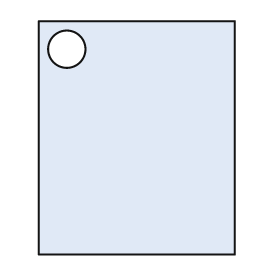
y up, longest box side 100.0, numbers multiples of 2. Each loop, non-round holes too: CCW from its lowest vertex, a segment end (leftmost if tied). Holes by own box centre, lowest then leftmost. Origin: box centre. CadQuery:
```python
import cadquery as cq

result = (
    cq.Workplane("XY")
    .moveTo(-42.0, -50.0)
    .lineTo(42.0, -50.0)
    .lineTo(42.0, 50.0)
    .lineTo(-42.0, 50.0)
    .close()
    .moveTo(-30.0, 38.0)
    .circle(8.0)
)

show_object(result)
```